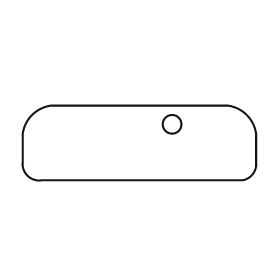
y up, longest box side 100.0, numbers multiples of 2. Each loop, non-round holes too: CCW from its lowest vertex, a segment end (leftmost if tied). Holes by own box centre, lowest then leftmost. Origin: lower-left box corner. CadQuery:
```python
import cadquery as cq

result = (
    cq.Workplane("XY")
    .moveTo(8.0, 0.0)
    .lineTo(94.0, 0.0)
    .threePointArc((98.0, 2.0), (100.0, 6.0))
    .lineTo(100.0, 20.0)
    .threePointArc((96.0, 28.0), (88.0, 32.0))
    .lineTo(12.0, 32.0)
    .threePointArc((4.0, 28.0), (0.0, 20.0))
    .lineTo(0.0, 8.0)
    .threePointArc((2.0, 2.0), (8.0, 0.0))
    .close()
    .moveTo(64.0, 24.0)
    .circle(4.0)
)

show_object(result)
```